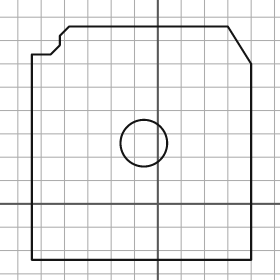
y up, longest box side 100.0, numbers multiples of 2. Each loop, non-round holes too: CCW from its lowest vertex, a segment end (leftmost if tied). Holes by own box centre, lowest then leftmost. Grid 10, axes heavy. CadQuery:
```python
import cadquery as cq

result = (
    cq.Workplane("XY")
    .moveTo(-54.0, -24.0)
    .lineTo(40.0, -24.0)
    .lineTo(40.0, 60.0)
    .lineTo(30.0, 76.0)
    .lineTo(-38.0, 76.0)
    .lineTo(-42.0, 72.0)
    .lineTo(-42.0, 68.0)
    .lineTo(-46.0, 64.0)
    .lineTo(-54.0, 64.0)
    .close()
    .moveTo(-6.0, 26.0)
    .circle(10.0)
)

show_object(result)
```